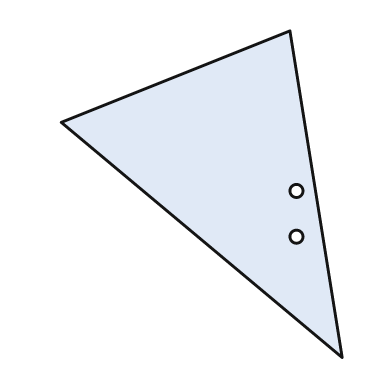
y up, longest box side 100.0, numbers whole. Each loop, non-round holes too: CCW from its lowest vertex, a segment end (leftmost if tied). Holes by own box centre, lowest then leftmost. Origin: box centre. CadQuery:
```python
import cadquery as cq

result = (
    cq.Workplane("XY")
    .moveTo(43.0, -50.0)
    .lineTo(27.0, 50.0)
    .lineTo(-43.0, 22.0)
    .close()
    .moveTo(29.0, -13.0)
    .circle(2.0)
    .moveTo(29.0, 1.0)
    .circle(2.0)
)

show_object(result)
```